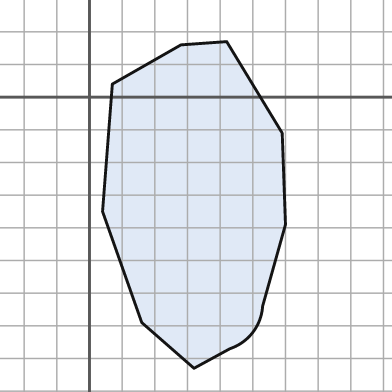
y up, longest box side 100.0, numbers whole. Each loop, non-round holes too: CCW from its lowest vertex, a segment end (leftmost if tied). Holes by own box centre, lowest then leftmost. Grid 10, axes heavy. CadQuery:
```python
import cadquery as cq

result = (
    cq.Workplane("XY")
    .moveTo(32.0, -83.0)
    .lineTo(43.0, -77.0)
    .threePointArc((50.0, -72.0), (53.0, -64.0))
    .lineTo(60.0, -39.0)
    .lineTo(59.0, -11.0)
    .lineTo(42.0, 17.0)
    .lineTo(28.0, 16.0)
    .lineTo(7.0, 4.0)
    .lineTo(4.0, -35.0)
    .lineTo(16.0, -69.0)
    .close()
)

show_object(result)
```